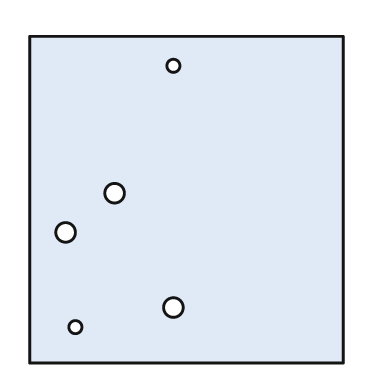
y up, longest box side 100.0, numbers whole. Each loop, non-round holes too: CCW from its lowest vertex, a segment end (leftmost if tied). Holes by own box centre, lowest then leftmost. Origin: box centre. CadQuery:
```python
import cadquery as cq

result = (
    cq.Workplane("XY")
    .moveTo(-48.0, -50.0)
    .lineTo(48.0, -50.0)
    .lineTo(48.0, 50.0)
    .lineTo(-48.0, 50.0)
    .close()
    .moveTo(-34.0, -39.0)
    .circle(2.0)
    .moveTo(-4.0, -33.0)
    .circle(3.0)
    .moveTo(-37.0, -10.0)
    .circle(3.0)
    .moveTo(-22.0, 2.0)
    .circle(3.0)
    .moveTo(-4.0, 41.0)
    .circle(2.0)
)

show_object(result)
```